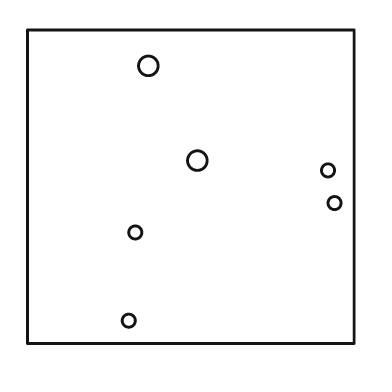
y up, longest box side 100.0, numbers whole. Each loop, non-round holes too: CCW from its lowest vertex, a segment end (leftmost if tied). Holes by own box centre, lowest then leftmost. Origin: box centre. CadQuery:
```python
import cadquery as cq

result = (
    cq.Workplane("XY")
    .moveTo(-50.0, -48.0)
    .lineTo(50.0, -48.0)
    .lineTo(50.0, 48.0)
    .lineTo(-50.0, 48.0)
    .close()
    .moveTo(-19.0, -41.0)
    .circle(2.0)
    .moveTo(-17.0, -14.0)
    .circle(2.0)
    .moveTo(44.0, -5.0)
    .circle(2.0)
    .moveTo(42.0, 5.0)
    .circle(2.0)
    .moveTo(2.0, 8.0)
    .circle(3.0)
    .moveTo(-13.0, 37.0)
    .circle(3.0)
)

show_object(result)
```